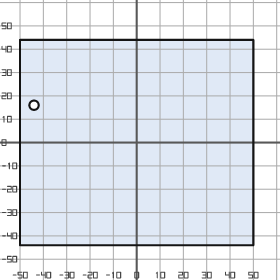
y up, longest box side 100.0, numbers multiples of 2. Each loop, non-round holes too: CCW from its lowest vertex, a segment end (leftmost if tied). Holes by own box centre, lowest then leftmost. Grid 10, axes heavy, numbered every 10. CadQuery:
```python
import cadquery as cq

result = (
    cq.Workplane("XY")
    .moveTo(-50.0, -44.0)
    .lineTo(50.0, -44.0)
    .lineTo(50.0, 44.0)
    .lineTo(-50.0, 44.0)
    .close()
    .moveTo(-44.0, 16.0)
    .circle(2.0)
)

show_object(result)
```